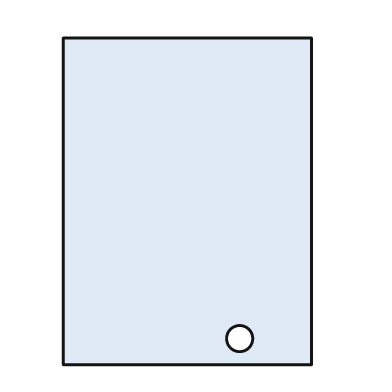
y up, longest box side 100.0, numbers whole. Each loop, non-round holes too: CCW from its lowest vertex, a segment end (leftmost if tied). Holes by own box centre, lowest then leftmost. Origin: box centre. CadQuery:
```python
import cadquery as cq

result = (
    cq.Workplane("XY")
    .moveTo(-38.0, -50.0)
    .lineTo(38.0, -50.0)
    .lineTo(38.0, 50.0)
    .lineTo(-38.0, 50.0)
    .close()
    .moveTo(16.0, -42.0)
    .circle(4.0)
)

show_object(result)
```